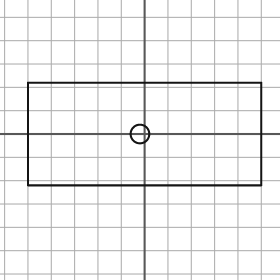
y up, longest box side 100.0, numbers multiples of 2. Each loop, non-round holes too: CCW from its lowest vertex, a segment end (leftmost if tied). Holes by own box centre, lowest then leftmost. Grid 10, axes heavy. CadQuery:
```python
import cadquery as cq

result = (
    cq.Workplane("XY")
    .moveTo(-50.0, -22.0)
    .lineTo(50.0, -22.0)
    .lineTo(50.0, 22.0)
    .lineTo(-50.0, 22.0)
    .close()
    .moveTo(-2.0, 0.0)
    .circle(4.0)
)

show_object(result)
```